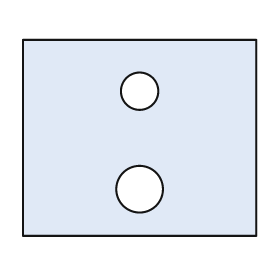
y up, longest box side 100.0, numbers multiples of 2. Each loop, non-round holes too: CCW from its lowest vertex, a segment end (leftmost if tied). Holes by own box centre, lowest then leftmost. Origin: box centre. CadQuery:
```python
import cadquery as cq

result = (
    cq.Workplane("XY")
    .moveTo(-50.0, -42.0)
    .lineTo(50.0, -42.0)
    .lineTo(50.0, 42.0)
    .lineTo(-50.0, 42.0)
    .close()
    .moveTo(0.0, -22.0)
    .circle(10.0)
    .moveTo(0.0, 20.0)
    .circle(8.0)
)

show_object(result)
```